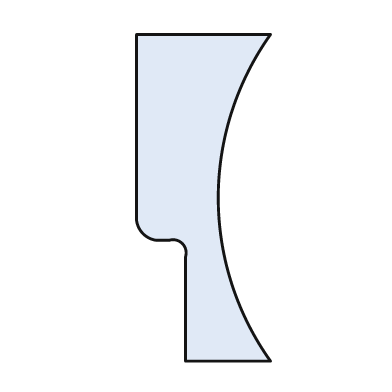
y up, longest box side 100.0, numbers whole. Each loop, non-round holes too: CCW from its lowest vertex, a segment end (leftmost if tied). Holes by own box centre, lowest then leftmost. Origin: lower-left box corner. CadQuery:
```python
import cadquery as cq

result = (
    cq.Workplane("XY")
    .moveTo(15.0, 0.0)
    .lineTo(41.0, 0.0)
    .threePointArc((25.0, 50.0), (41.0, 100.0))
    .lineTo(0.0, 100.0)
    .lineTo(0.0, 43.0)
    .threePointArc((2.0, 39.0), (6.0, 37.0))
    .lineTo(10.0, 37.0)
    .threePointArc((14.0, 36.0), (15.0, 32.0))
    .close()
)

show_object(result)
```